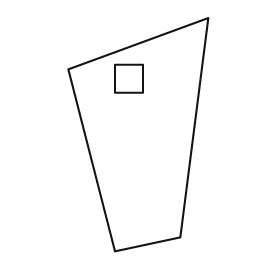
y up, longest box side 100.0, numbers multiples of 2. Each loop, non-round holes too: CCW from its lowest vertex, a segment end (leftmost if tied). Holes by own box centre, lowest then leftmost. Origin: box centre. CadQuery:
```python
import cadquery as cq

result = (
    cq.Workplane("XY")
    .moveTo(-10.0, -50.0)
    .lineTo(18.0, -44.0)
    .lineTo(30.0, 50.0)
    .lineTo(-30.0, 28.0)
    .close()
    .moveTo(-10.0, 18.0)
    .lineTo(2.0, 18.0)
    .lineTo(2.0, 30.0)
    .lineTo(-10.0, 30.0)
    .close()
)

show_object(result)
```